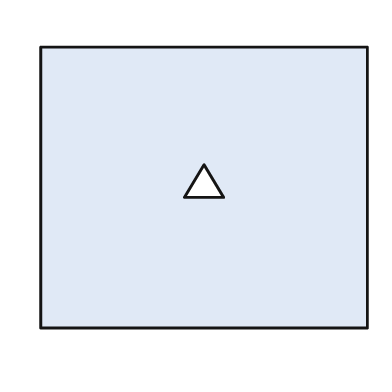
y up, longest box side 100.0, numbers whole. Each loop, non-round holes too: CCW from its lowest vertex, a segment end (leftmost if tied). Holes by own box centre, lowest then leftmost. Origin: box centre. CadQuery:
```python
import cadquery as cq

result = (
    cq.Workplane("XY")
    .moveTo(-50.0, -43.0)
    .lineTo(50.0, -43.0)
    .lineTo(50.0, 43.0)
    .lineTo(-50.0, 43.0)
    .close()
    .moveTo(-6.0, -3.0)
    .lineTo(6.0, -3.0)
    .lineTo(0.0, 7.0)
    .close()
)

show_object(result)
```